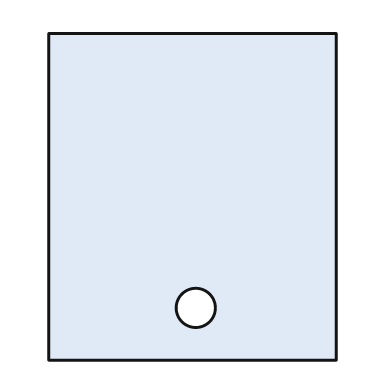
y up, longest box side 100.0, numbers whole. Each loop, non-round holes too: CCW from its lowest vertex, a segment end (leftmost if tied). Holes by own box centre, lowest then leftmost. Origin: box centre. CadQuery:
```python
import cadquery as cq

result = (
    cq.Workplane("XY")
    .moveTo(-44.0, -50.0)
    .lineTo(44.0, -50.0)
    .lineTo(44.0, 50.0)
    .lineTo(-44.0, 50.0)
    .close()
    .moveTo(1.0, -34.0)
    .circle(6.0)
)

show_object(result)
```